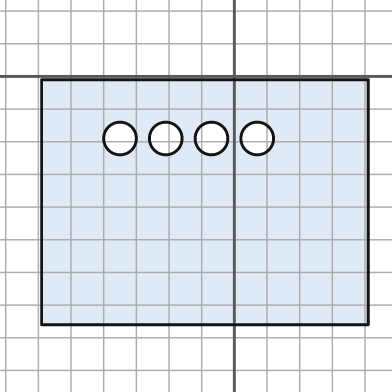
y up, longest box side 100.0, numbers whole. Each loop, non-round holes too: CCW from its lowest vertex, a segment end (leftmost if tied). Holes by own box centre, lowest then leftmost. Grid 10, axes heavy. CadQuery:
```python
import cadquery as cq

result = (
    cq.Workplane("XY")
    .moveTo(-59.0, -76.0)
    .lineTo(41.0, -76.0)
    .lineTo(41.0, -1.0)
    .lineTo(-59.0, -1.0)
    .close()
    .moveTo(-35.0, -19.0)
    .circle(5.0)
    .moveTo(-21.0, -19.0)
    .circle(5.0)
    .moveTo(-7.0, -19.0)
    .circle(5.0)
    .moveTo(7.0, -19.0)
    .circle(5.0)
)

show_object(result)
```